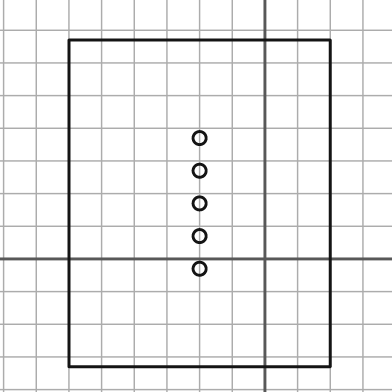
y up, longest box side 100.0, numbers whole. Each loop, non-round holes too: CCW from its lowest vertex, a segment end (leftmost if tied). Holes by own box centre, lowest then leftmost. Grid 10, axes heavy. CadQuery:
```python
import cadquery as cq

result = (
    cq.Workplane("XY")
    .moveTo(-60.0, -33.0)
    .lineTo(20.0, -33.0)
    .lineTo(20.0, 67.0)
    .lineTo(-60.0, 67.0)
    .close()
    .moveTo(-20.0, -3.0)
    .circle(2.0)
    .moveTo(-20.0, 7.0)
    .circle(2.0)
    .moveTo(-20.0, 17.0)
    .circle(2.0)
    .moveTo(-20.0, 27.0)
    .circle(2.0)
    .moveTo(-20.0, 37.0)
    .circle(2.0)
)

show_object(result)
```